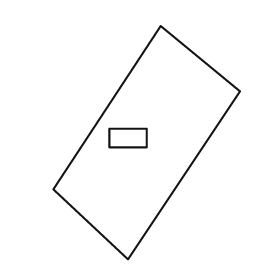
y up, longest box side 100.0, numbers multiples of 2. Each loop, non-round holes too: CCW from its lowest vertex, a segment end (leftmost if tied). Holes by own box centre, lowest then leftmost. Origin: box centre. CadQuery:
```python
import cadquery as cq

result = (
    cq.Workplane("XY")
    .moveTo(-8.0, -50.0)
    .lineTo(40.0, 22.0)
    .lineTo(6.0, 50.0)
    .lineTo(-40.0, -20.0)
    .close()
    .moveTo(-16.0, -2.0)
    .lineTo(0.0, -2.0)
    .lineTo(0.0, 6.0)
    .lineTo(-16.0, 6.0)
    .close()
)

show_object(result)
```